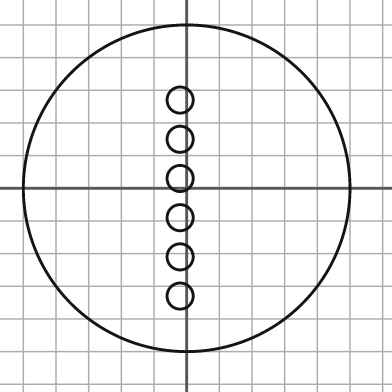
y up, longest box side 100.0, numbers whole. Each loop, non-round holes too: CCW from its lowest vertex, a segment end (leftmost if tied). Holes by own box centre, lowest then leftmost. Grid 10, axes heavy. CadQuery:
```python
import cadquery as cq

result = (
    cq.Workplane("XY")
    .moveTo(0.0, 0.0)
    .circle(50.0)
    .moveTo(-2.0, -33.0)
    .circle(4.0)
    .moveTo(-2.0, -21.0)
    .circle(4.0)
    .moveTo(-2.0, -9.0)
    .circle(4.0)
    .moveTo(-2.0, 3.0)
    .circle(4.0)
    .moveTo(-2.0, 15.0)
    .circle(4.0)
    .moveTo(-2.0, 27.0)
    .circle(4.0)
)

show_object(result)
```